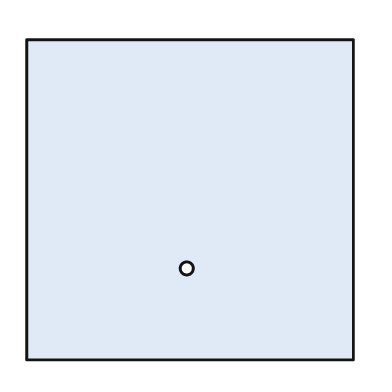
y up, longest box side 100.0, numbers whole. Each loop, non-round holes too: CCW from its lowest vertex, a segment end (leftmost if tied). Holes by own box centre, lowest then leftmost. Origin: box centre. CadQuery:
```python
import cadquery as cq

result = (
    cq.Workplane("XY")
    .moveTo(-50.0, -49.0)
    .lineTo(50.0, -49.0)
    .lineTo(50.0, 49.0)
    .lineTo(-50.0, 49.0)
    .close()
    .moveTo(-1.0, -21.0)
    .circle(2.0)
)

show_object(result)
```